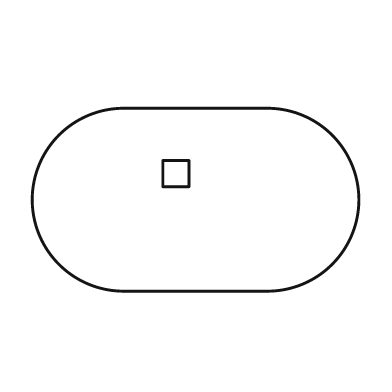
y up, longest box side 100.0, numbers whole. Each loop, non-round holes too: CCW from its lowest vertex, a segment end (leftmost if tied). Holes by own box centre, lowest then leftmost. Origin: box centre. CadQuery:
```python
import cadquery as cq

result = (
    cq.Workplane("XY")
    .moveTo(-22.0, -28.0)
    .lineTo(22.0, -28.0)
    .threePointArc((50.0, 0.0), (22.0, 28.0))
    .lineTo(-22.0, 28.0)
    .threePointArc((-50.0, 0.0), (-22.0, -28.0))
    .close()
    .moveTo(-10.0, 4.0)
    .lineTo(-2.0, 4.0)
    .lineTo(-2.0, 12.0)
    .lineTo(-10.0, 12.0)
    .close()
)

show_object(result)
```